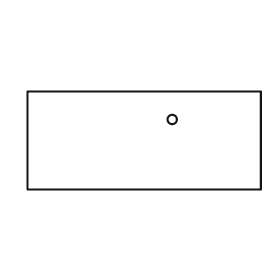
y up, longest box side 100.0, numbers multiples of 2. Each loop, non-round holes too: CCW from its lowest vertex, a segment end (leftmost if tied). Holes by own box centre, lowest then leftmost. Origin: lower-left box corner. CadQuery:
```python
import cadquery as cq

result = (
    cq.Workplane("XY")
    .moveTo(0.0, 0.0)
    .lineTo(100.0, 0.0)
    .lineTo(100.0, 42.0)
    .lineTo(0.0, 42.0)
    .close()
    .moveTo(62.0, 30.0)
    .circle(2.0)
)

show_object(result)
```